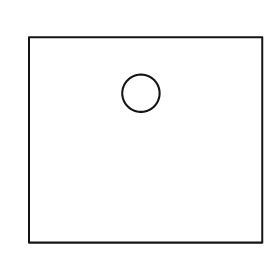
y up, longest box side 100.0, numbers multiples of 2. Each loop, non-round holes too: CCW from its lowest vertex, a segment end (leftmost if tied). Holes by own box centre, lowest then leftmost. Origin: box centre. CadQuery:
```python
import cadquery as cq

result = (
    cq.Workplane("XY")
    .moveTo(-50.0, -44.0)
    .lineTo(50.0, -44.0)
    .lineTo(50.0, 44.0)
    .lineTo(-50.0, 44.0)
    .close()
    .moveTo(-2.0, 20.0)
    .circle(8.0)
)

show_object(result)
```